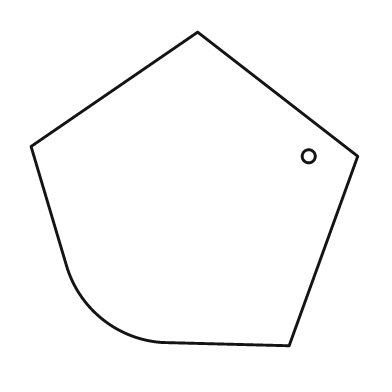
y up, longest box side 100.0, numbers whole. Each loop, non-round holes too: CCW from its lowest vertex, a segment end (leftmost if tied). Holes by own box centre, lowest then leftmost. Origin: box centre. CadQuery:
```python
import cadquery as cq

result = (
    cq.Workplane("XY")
    .moveTo(29.0, -48.0)
    .lineTo(50.0, 10.0)
    .lineTo(1.0, 48.0)
    .lineTo(-50.0, 13.0)
    .lineTo(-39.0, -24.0)
    .threePointArc((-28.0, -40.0), (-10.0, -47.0))
    .close()
    .moveTo(35.0, 10.0)
    .circle(2.0)
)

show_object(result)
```